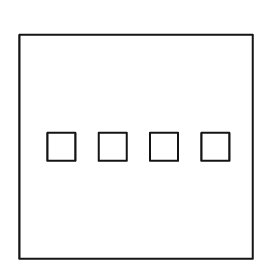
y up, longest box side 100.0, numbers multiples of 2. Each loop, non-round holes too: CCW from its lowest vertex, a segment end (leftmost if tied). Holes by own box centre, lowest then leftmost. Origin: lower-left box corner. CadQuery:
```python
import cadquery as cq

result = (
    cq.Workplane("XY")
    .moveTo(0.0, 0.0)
    .lineTo(100.0, 0.0)
    .lineTo(100.0, 96.0)
    .lineTo(0.0, 96.0)
    .close()
    .moveTo(12.0, 42.0)
    .lineTo(24.0, 42.0)
    .lineTo(24.0, 54.0)
    .lineTo(12.0, 54.0)
    .close()
    .moveTo(34.0, 42.0)
    .lineTo(46.0, 42.0)
    .lineTo(46.0, 54.0)
    .lineTo(34.0, 54.0)
    .close()
    .moveTo(56.0, 42.0)
    .lineTo(68.0, 42.0)
    .lineTo(68.0, 54.0)
    .lineTo(56.0, 54.0)
    .close()
    .moveTo(78.0, 42.0)
    .lineTo(90.0, 42.0)
    .lineTo(90.0, 54.0)
    .lineTo(78.0, 54.0)
    .close()
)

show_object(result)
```